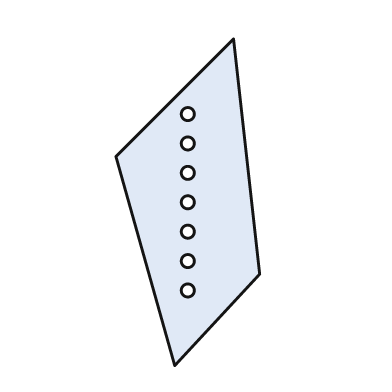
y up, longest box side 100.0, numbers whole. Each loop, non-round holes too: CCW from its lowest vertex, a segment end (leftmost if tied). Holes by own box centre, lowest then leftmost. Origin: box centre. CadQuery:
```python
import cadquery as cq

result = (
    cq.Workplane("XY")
    .moveTo(-4.0, -50.0)
    .lineTo(22.0, -22.0)
    .lineTo(14.0, 50.0)
    .lineTo(-22.0, 14.0)
    .close()
    .moveTo(0.0, -27.0)
    .circle(2.0)
    .moveTo(0.0, -18.0)
    .circle(2.0)
    .moveTo(0.0, -9.0)
    .circle(2.0)
    .moveTo(0.0, 0.0)
    .circle(2.0)
    .moveTo(0.0, 9.0)
    .circle(2.0)
    .moveTo(0.0, 18.0)
    .circle(2.0)
    .moveTo(0.0, 27.0)
    .circle(2.0)
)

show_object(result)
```